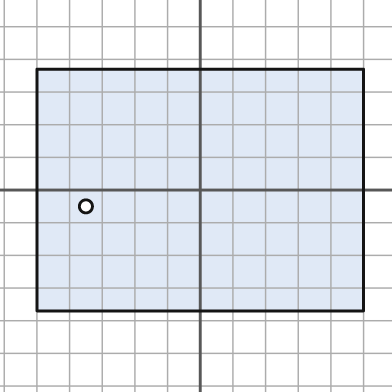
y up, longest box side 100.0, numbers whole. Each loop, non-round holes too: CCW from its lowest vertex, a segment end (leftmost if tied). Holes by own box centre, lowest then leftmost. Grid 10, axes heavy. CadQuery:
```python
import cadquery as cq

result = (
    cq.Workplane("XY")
    .moveTo(-50.0, -37.0)
    .lineTo(50.0, -37.0)
    .lineTo(50.0, 37.0)
    .lineTo(-50.0, 37.0)
    .close()
    .moveTo(-35.0, -5.0)
    .circle(2.0)
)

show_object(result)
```